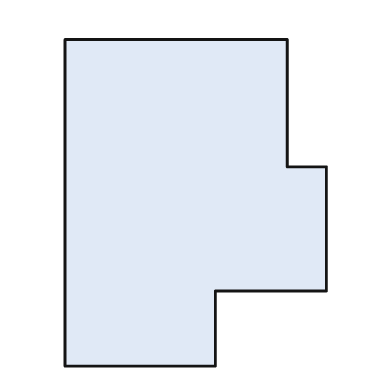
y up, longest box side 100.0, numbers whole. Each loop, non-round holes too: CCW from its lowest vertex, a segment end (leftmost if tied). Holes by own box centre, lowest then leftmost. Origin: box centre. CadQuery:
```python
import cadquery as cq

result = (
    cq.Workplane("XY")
    .moveTo(-40.0, -50.0)
    .lineTo(6.0, -50.0)
    .lineTo(6.0, -27.0)
    .lineTo(40.0, -27.0)
    .lineTo(40.0, 11.0)
    .lineTo(28.0, 11.0)
    .lineTo(28.0, 50.0)
    .lineTo(-40.0, 50.0)
    .close()
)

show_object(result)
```